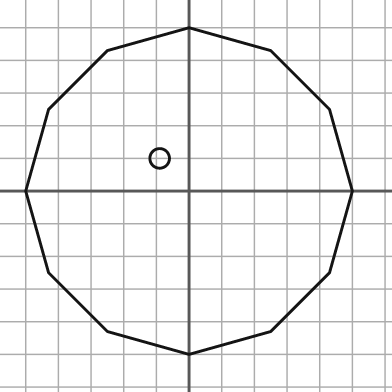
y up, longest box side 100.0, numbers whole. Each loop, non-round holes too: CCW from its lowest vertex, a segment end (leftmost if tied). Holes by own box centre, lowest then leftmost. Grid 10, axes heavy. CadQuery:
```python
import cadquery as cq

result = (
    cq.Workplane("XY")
    .moveTo(0.0, -50.0)
    .lineTo(25.0, -43.0)
    .lineTo(43.0, -25.0)
    .lineTo(50.0, 0.0)
    .lineTo(43.0, 25.0)
    .lineTo(25.0, 43.0)
    .lineTo(0.0, 50.0)
    .lineTo(-25.0, 43.0)
    .lineTo(-43.0, 25.0)
    .lineTo(-50.0, 0.0)
    .lineTo(-43.0, -25.0)
    .lineTo(-25.0, -43.0)
    .close()
    .moveTo(-9.0, 10.0)
    .circle(3.0)
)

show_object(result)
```